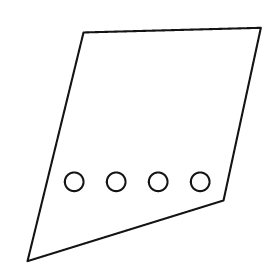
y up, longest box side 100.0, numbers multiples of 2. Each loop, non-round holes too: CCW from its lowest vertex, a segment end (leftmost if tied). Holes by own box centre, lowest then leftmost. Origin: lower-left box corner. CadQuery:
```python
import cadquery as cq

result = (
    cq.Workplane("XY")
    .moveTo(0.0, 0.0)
    .lineTo(84.0, 26.0)
    .lineTo(100.0, 100.0)
    .lineTo(24.0, 98.0)
    .close()
    .moveTo(20.0, 34.0)
    .circle(4.0)
    .moveTo(38.0, 34.0)
    .circle(4.0)
    .moveTo(56.0, 34.0)
    .circle(4.0)
    .moveTo(74.0, 34.0)
    .circle(4.0)
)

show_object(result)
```